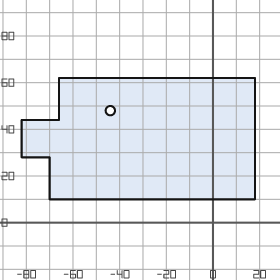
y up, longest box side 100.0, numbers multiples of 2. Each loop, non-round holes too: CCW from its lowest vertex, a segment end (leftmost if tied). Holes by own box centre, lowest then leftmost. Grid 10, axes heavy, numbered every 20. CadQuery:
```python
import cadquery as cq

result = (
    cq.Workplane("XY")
    .moveTo(-70.0, 10.0)
    .lineTo(18.0, 10.0)
    .lineTo(18.0, 62.0)
    .lineTo(-66.0, 62.0)
    .lineTo(-66.0, 44.0)
    .lineTo(-82.0, 44.0)
    .lineTo(-82.0, 28.0)
    .lineTo(-70.0, 28.0)
    .close()
    .moveTo(-44.0, 48.0)
    .circle(2.0)
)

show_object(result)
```